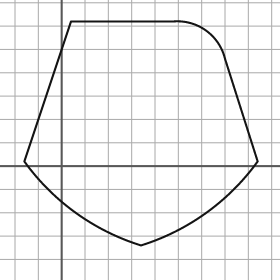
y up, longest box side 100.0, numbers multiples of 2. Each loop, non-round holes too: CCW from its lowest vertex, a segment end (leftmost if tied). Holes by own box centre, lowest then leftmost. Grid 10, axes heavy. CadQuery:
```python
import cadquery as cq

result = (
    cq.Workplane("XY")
    .moveTo(34.0, -34.0)
    .threePointArc((62.0, -20.0), (84.0, 2.0))
    .lineTo(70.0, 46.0)
    .threePointArc((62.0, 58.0), (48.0, 62.0))
    .lineTo(4.0, 62.0)
    .lineTo(-16.0, 2.0)
    .threePointArc((6.0, -20.0), (34.0, -34.0))
    .close()
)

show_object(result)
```